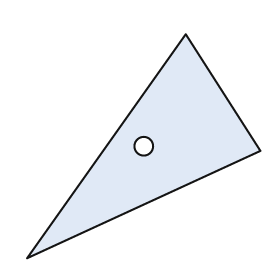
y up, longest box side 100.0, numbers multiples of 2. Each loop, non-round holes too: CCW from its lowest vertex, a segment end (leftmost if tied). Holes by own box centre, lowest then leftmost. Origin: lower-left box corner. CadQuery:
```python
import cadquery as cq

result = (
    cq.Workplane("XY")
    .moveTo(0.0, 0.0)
    .lineTo(100.0, 46.0)
    .lineTo(68.0, 96.0)
    .close()
    .moveTo(50.0, 48.0)
    .circle(4.0)
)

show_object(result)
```